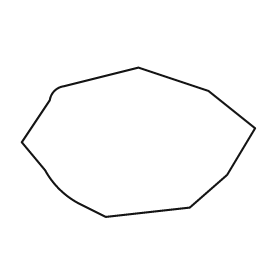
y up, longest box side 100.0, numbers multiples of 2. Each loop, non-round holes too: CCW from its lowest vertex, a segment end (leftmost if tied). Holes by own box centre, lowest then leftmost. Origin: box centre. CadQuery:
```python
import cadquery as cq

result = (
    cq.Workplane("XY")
    .moveTo(-14.0, -32.0)
    .lineTo(22.0, -28.0)
    .lineTo(38.0, -14.0)
    .lineTo(50.0, 6.0)
    .lineTo(30.0, 22.0)
    .lineTo(0.0, 32.0)
    .lineTo(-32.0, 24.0)
    .threePointArc((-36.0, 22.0), (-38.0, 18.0))
    .lineTo(-50.0, 0.0)
    .lineTo(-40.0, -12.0)
    .threePointArc((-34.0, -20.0), (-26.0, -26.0))
    .close()
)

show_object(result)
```